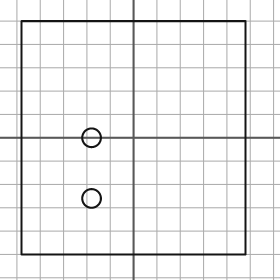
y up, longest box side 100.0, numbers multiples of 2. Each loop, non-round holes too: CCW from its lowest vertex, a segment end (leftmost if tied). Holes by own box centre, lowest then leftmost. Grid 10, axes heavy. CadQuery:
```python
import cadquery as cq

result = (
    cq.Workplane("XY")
    .moveTo(-48.0, -50.0)
    .lineTo(48.0, -50.0)
    .lineTo(48.0, 50.0)
    .lineTo(-48.0, 50.0)
    .close()
    .moveTo(-18.0, -26.0)
    .circle(4.0)
    .moveTo(-18.0, 0.0)
    .circle(4.0)
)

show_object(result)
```